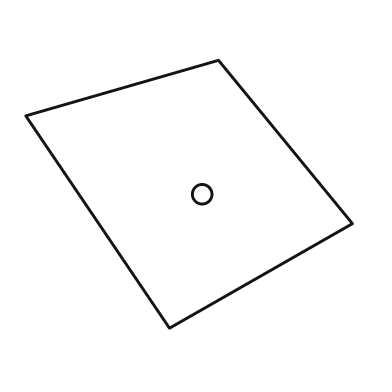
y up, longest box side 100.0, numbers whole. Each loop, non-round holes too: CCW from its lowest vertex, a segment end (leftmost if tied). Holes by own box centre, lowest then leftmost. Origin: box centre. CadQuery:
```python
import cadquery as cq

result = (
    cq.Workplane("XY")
    .moveTo(-6.0, -41.0)
    .lineTo(50.0, -9.0)
    .lineTo(9.0, 41.0)
    .lineTo(-50.0, 24.0)
    .close()
    .moveTo(4.0, 0.0)
    .circle(3.0)
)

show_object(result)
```